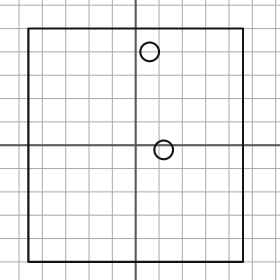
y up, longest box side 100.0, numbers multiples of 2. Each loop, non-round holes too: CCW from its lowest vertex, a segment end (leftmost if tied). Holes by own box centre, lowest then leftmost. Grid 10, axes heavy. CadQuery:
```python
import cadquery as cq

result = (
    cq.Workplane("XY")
    .moveTo(-46.0, -50.0)
    .lineTo(46.0, -50.0)
    .lineTo(46.0, 50.0)
    .lineTo(-46.0, 50.0)
    .close()
    .moveTo(12.0, -2.0)
    .circle(4.0)
    .moveTo(6.0, 40.0)
    .circle(4.0)
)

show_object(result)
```